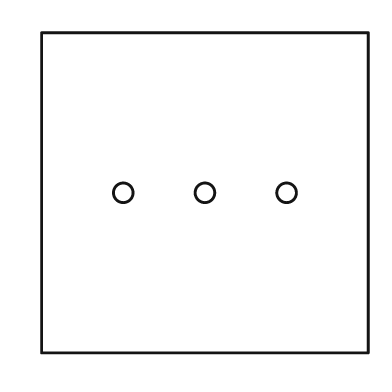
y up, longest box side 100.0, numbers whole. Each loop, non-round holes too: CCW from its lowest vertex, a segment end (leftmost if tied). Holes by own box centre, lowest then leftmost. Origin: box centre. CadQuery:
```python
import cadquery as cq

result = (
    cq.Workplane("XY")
    .moveTo(-50.0, -49.0)
    .lineTo(50.0, -49.0)
    .lineTo(50.0, 49.0)
    .lineTo(-50.0, 49.0)
    .close()
    .moveTo(-25.0, 0.0)
    .circle(3.0)
    .moveTo(0.0, 0.0)
    .circle(3.0)
    .moveTo(25.0, 0.0)
    .circle(3.0)
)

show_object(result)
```